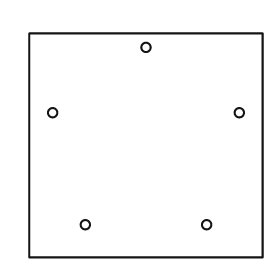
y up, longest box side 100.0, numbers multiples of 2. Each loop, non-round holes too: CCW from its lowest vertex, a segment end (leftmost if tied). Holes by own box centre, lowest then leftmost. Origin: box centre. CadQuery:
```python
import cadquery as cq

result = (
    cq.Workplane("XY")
    .moveTo(-50.0, -48.0)
    .lineTo(50.0, -48.0)
    .lineTo(50.0, 48.0)
    .lineTo(-50.0, 48.0)
    .close()
    .moveTo(-26.0, -34.0)
    .circle(2.0)
    .moveTo(26.0, -34.0)
    .circle(2.0)
    .moveTo(-40.0, 14.0)
    .circle(2.0)
    .moveTo(40.0, 14.0)
    .circle(2.0)
    .moveTo(0.0, 42.0)
    .circle(2.0)
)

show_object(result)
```